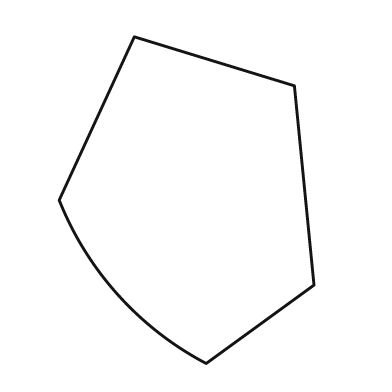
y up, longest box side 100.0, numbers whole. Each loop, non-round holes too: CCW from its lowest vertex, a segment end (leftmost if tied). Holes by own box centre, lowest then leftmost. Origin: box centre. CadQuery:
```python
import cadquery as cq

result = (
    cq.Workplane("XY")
    .moveTo(6.0, -50.0)
    .lineTo(39.0, -26.0)
    .lineTo(33.0, 35.0)
    .lineTo(-16.0, 50.0)
    .lineTo(-39.0, 0.0)
    .threePointArc((-21.0, -29.0), (6.0, -50.0))
    .close()
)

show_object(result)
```